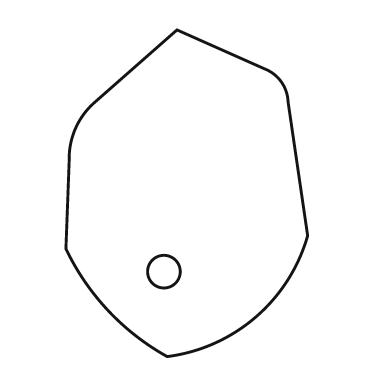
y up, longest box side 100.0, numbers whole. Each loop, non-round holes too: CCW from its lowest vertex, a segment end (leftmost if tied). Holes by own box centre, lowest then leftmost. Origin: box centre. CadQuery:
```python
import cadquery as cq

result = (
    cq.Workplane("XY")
    .moveTo(-6.0, -50.0)
    .threePointArc((21.0, -38.0), (37.0, -13.0))
    .lineTo(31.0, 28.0)
    .threePointArc((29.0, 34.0), (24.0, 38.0))
    .lineTo(-3.0, 50.0)
    .lineTo(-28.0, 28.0)
    .threePointArc((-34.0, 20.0), (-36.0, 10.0))
    .lineTo(-37.0, -17.0)
    .threePointArc((-24.0, -36.0), (-6.0, -50.0))
    .close()
    .moveTo(-7.0, -24.0)
    .circle(5.0)
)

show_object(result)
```